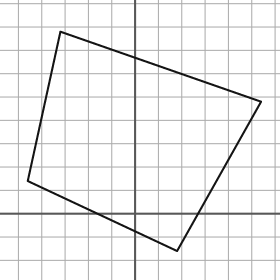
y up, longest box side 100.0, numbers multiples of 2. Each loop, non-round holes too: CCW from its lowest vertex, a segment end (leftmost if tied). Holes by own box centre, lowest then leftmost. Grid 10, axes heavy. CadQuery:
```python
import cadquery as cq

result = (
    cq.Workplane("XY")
    .moveTo(18.0, -16.0)
    .lineTo(54.0, 48.0)
    .lineTo(-32.0, 78.0)
    .lineTo(-46.0, 14.0)
    .close()
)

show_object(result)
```